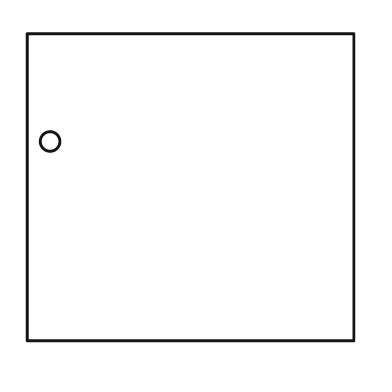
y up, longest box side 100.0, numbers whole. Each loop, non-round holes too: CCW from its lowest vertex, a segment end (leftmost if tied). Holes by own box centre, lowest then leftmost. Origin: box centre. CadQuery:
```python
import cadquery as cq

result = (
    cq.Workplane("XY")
    .moveTo(-50.0, -47.0)
    .lineTo(50.0, -47.0)
    .lineTo(50.0, 47.0)
    .lineTo(-50.0, 47.0)
    .close()
    .moveTo(-43.0, 14.0)
    .circle(3.0)
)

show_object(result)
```